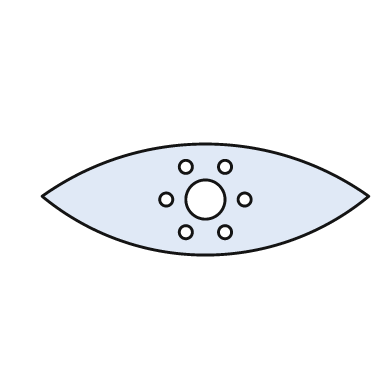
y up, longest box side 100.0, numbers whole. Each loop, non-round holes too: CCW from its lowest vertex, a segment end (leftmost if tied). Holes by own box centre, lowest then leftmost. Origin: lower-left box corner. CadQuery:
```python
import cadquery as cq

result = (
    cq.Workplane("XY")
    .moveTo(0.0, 18.0)
    .threePointArc((50.0, 0.0), (100.0, 18.0))
    .threePointArc((50.0, 34.0), (0.0, 18.0))
    .close()
    .moveTo(44.0, 7.0)
    .circle(2.0)
    .moveTo(56.0, 7.0)
    .circle(2.0)
    .moveTo(38.0, 17.0)
    .circle(2.0)
    .moveTo(50.0, 17.0)
    .circle(6.0)
    .moveTo(62.0, 17.0)
    .circle(2.0)
    .moveTo(44.0, 27.0)
    .circle(2.0)
    .moveTo(56.0, 27.0)
    .circle(2.0)
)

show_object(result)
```